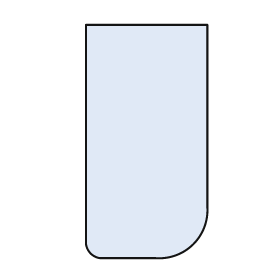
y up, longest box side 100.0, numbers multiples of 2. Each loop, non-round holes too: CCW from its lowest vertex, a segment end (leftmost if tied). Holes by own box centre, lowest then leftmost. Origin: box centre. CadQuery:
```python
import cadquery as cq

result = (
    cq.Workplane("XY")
    .moveTo(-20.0, -50.0)
    .lineTo(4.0, -50.0)
    .threePointArc((20.0, -44.0), (26.0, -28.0))
    .lineTo(26.0, 50.0)
    .lineTo(-26.0, 50.0)
    .lineTo(-26.0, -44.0)
    .threePointArc((-24.0, -48.0), (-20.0, -50.0))
    .close()
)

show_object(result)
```